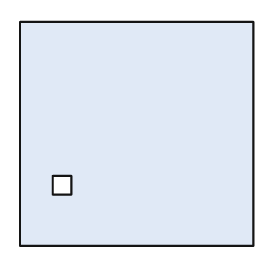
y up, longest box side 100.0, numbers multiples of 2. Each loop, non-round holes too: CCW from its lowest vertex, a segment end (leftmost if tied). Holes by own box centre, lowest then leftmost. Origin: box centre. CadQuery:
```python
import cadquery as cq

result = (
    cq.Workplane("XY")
    .moveTo(-50.0, -48.0)
    .lineTo(50.0, -48.0)
    .lineTo(50.0, 48.0)
    .lineTo(-50.0, 48.0)
    .close()
    .moveTo(-36.0, -26.0)
    .lineTo(-28.0, -26.0)
    .lineTo(-28.0, -18.0)
    .lineTo(-36.0, -18.0)
    .close()
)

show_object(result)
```